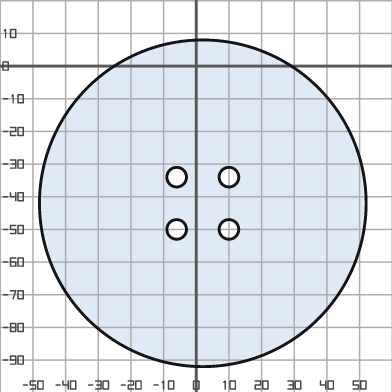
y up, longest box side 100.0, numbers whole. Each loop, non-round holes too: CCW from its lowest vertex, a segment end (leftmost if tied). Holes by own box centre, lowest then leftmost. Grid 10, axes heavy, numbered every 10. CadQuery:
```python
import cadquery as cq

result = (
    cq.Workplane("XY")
    .moveTo(2.0, -42.0)
    .circle(50.0)
    .moveTo(-6.0, -50.0)
    .circle(3.0)
    .moveTo(10.0, -50.0)
    .circle(3.0)
    .moveTo(-6.0, -34.0)
    .circle(3.0)
    .moveTo(10.0, -34.0)
    .circle(3.0)
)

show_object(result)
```